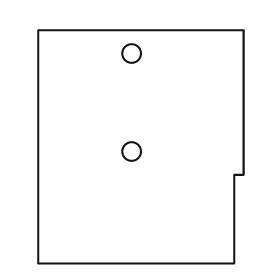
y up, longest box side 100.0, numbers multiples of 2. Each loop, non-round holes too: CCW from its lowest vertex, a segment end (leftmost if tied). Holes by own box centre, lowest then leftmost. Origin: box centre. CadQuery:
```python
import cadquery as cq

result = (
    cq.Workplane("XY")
    .moveTo(-44.0, -50.0)
    .lineTo(40.0, -50.0)
    .lineTo(40.0, -12.0)
    .lineTo(44.0, -12.0)
    .lineTo(44.0, 50.0)
    .lineTo(-44.0, 50.0)
    .close()
    .moveTo(-4.0, -2.0)
    .circle(4.0)
    .moveTo(-4.0, 40.0)
    .circle(4.0)
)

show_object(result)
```